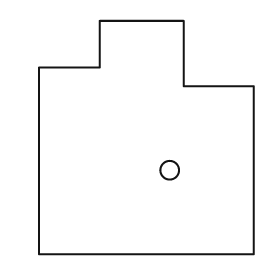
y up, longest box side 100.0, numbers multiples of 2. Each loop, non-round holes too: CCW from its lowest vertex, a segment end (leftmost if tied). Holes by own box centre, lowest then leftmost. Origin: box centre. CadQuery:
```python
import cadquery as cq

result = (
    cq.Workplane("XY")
    .moveTo(-46.0, -50.0)
    .lineTo(46.0, -50.0)
    .lineTo(46.0, 22.0)
    .lineTo(16.0, 22.0)
    .lineTo(16.0, 50.0)
    .lineTo(-20.0, 50.0)
    .lineTo(-20.0, 30.0)
    .lineTo(-46.0, 30.0)
    .close()
    .moveTo(10.0, -14.0)
    .circle(4.0)
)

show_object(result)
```